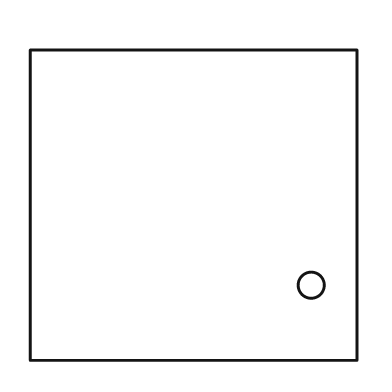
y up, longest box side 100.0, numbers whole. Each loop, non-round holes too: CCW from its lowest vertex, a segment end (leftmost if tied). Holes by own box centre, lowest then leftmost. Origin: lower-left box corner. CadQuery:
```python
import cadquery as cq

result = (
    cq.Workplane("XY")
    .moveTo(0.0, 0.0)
    .lineTo(100.0, 0.0)
    .lineTo(100.0, 95.0)
    .lineTo(0.0, 95.0)
    .close()
    .moveTo(86.0, 23.0)
    .circle(4.0)
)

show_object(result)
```